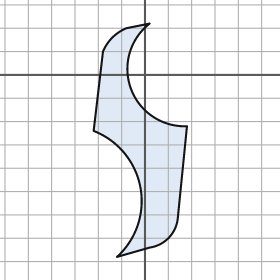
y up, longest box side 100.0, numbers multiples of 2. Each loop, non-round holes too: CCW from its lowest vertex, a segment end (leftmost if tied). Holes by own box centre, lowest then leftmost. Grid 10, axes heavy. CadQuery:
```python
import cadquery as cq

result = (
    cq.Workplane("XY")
    .moveTo(-12.0, -78.0)
    .lineTo(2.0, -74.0)
    .threePointArc((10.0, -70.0), (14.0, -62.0))
    .lineTo(18.0, -22.0)
    .threePointArc((-6.0, -6.0), (2.0, 22.0))
    .lineTo(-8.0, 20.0)
    .threePointArc((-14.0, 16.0), (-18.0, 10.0))
    .lineTo(-22.0, -24.0)
    .threePointArc((-2.0, -48.0), (-12.0, -78.0))
    .close()
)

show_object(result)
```